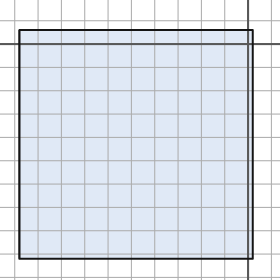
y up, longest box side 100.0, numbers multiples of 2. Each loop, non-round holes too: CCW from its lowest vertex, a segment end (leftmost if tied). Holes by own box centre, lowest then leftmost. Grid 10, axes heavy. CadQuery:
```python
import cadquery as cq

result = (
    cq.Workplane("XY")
    .moveTo(-98.0, -92.0)
    .lineTo(2.0, -92.0)
    .lineTo(2.0, 6.0)
    .lineTo(-98.0, 6.0)
    .close()
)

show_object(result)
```